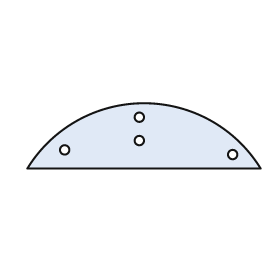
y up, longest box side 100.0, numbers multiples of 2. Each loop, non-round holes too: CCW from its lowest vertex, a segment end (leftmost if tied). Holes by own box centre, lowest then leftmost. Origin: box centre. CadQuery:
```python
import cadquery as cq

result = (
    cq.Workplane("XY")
    .moveTo(-50.0, -14.0)
    .lineTo(50.0, -14.0)
    .threePointArc((0.0, 14.0), (-50.0, -14.0))
    .close()
    .moveTo(38.0, -8.0)
    .circle(2.0)
    .moveTo(-34.0, -6.0)
    .circle(2.0)
    .moveTo(-2.0, -2.0)
    .circle(2.0)
    .moveTo(-2.0, 8.0)
    .circle(2.0)
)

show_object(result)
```